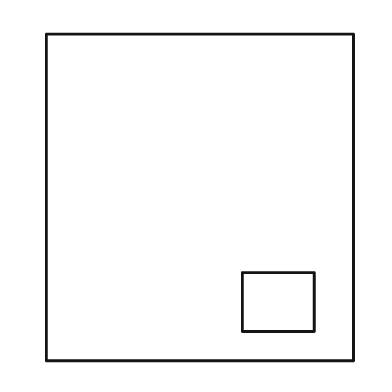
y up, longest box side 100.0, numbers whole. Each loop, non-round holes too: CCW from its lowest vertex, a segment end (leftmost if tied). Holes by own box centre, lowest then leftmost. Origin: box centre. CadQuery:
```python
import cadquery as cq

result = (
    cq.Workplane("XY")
    .moveTo(-47.0, -50.0)
    .lineTo(47.0, -50.0)
    .lineTo(47.0, 50.0)
    .lineTo(-47.0, 50.0)
    .close()
    .moveTo(13.0, -41.0)
    .lineTo(35.0, -41.0)
    .lineTo(35.0, -23.0)
    .lineTo(13.0, -23.0)
    .close()
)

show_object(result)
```